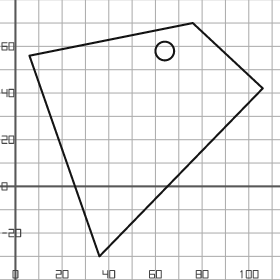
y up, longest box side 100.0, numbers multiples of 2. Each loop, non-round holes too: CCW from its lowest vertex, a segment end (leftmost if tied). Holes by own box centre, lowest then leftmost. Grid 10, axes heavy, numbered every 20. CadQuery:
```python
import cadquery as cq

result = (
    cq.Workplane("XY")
    .moveTo(36.0, -30.0)
    .lineTo(106.0, 42.0)
    .lineTo(76.0, 70.0)
    .lineTo(6.0, 56.0)
    .close()
    .moveTo(64.0, 58.0)
    .circle(4.0)
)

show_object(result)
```